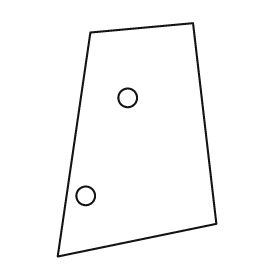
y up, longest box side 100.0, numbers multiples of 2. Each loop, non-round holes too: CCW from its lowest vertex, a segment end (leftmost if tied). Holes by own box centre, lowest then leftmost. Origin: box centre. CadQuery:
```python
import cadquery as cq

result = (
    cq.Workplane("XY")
    .moveTo(-34.0, -50.0)
    .lineTo(34.0, -36.0)
    .lineTo(24.0, 50.0)
    .lineTo(-20.0, 46.0)
    .close()
    .moveTo(-22.0, -24.0)
    .circle(4.0)
    .moveTo(-4.0, 18.0)
    .circle(4.0)
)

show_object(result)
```